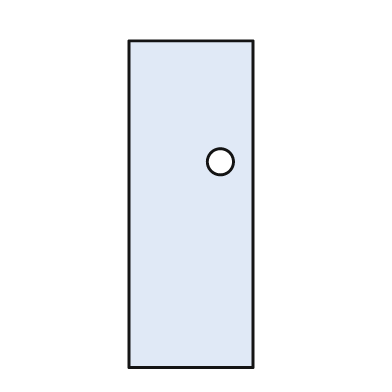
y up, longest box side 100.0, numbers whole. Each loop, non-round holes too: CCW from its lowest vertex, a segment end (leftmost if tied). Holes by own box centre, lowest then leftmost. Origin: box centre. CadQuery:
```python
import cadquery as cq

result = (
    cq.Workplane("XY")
    .moveTo(-19.0, -50.0)
    .lineTo(19.0, -50.0)
    .lineTo(19.0, 50.0)
    .lineTo(-19.0, 50.0)
    .close()
    .moveTo(9.0, 13.0)
    .circle(4.0)
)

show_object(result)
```